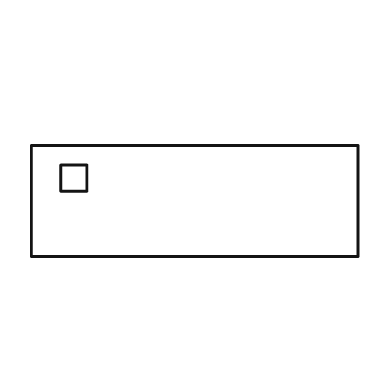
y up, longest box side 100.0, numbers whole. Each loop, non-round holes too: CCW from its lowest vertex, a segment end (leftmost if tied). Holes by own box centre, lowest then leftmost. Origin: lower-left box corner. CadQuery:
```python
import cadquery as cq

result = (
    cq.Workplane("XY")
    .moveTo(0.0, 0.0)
    .lineTo(100.0, 0.0)
    .lineTo(100.0, 34.0)
    .lineTo(0.0, 34.0)
    .close()
    .moveTo(9.0, 20.0)
    .lineTo(17.0, 20.0)
    .lineTo(17.0, 28.0)
    .lineTo(9.0, 28.0)
    .close()
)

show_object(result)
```